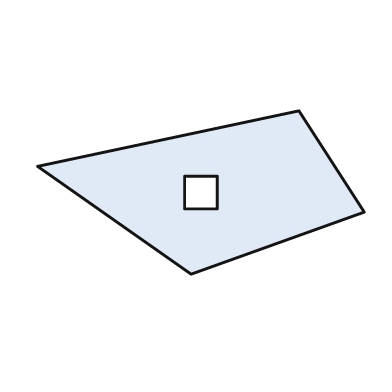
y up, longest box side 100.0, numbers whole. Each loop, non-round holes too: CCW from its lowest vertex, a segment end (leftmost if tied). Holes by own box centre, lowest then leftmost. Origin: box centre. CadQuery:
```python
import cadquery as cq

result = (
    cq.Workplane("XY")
    .moveTo(-3.0, -25.0)
    .lineTo(50.0, -6.0)
    .lineTo(30.0, 25.0)
    .lineTo(-50.0, 8.0)
    .close()
    .moveTo(-5.0, -5.0)
    .lineTo(5.0, -5.0)
    .lineTo(5.0, 5.0)
    .lineTo(-5.0, 5.0)
    .close()
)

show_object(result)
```